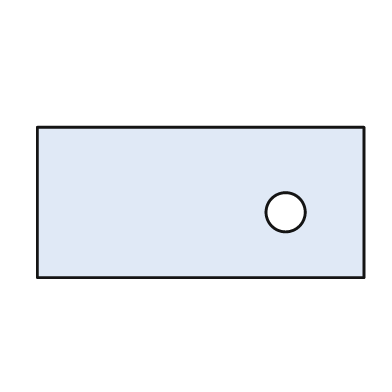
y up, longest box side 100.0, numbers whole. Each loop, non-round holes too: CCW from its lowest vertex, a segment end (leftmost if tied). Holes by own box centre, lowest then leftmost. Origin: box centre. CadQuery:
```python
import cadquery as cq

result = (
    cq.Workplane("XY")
    .moveTo(-50.0, -23.0)
    .lineTo(50.0, -23.0)
    .lineTo(50.0, 23.0)
    .lineTo(-50.0, 23.0)
    .close()
    .moveTo(26.0, -3.0)
    .circle(6.0)
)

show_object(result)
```